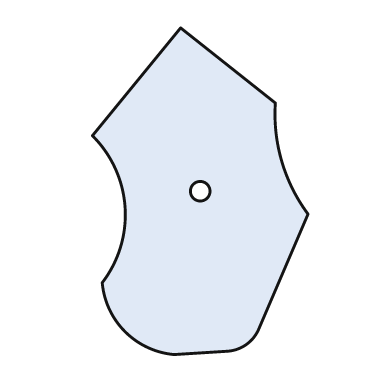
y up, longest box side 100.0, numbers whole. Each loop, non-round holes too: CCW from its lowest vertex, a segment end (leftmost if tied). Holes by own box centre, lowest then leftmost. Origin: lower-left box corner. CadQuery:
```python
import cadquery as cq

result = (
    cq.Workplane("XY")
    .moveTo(25.0, 0.0)
    .lineTo(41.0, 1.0)
    .threePointArc((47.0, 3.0), (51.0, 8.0))
    .lineTo(66.0, 43.0)
    .threePointArc((58.0, 59.0), (56.0, 77.0))
    .lineTo(27.0, 100.0)
    .lineTo(0.0, 67.0)
    .threePointArc((10.0, 45.0), (3.0, 22.0))
    .threePointArc((10.0, 7.0), (25.0, 0.0))
    .close()
    .moveTo(33.0, 50.0)
    .circle(3.0)
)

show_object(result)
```